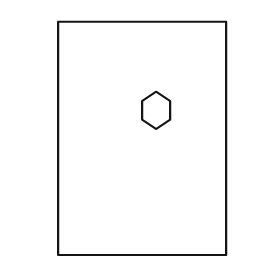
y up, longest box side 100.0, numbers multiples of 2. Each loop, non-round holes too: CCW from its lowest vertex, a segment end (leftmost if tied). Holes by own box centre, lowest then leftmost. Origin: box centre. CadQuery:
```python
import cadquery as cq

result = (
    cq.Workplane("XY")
    .moveTo(-36.0, -50.0)
    .lineTo(36.0, -50.0)
    .lineTo(36.0, 50.0)
    .lineTo(-36.0, 50.0)
    .close()
    .moveTo(6.0, 4.0)
    .lineTo(12.0, 8.0)
    .lineTo(12.0, 16.0)
    .lineTo(6.0, 20.0)
    .lineTo(0.0, 16.0)
    .lineTo(0.0, 8.0)
    .close()
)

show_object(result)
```